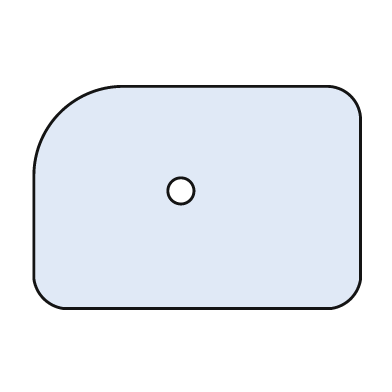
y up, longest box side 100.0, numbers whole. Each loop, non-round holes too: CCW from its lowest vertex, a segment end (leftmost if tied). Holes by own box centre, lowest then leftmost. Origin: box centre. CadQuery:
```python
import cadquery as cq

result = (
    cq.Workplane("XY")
    .moveTo(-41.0, -34.0)
    .lineTo(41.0, -34.0)
    .threePointArc((47.0, -31.0), (50.0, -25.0))
    .lineTo(50.0, 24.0)
    .threePointArc((47.0, 31.0), (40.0, 34.0))
    .lineTo(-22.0, 34.0)
    .threePointArc((-42.0, 26.0), (-50.0, 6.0))
    .lineTo(-50.0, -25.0)
    .threePointArc((-47.0, -31.0), (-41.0, -34.0))
    .close()
    .moveTo(-5.0, 2.0)
    .circle(4.0)
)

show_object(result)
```